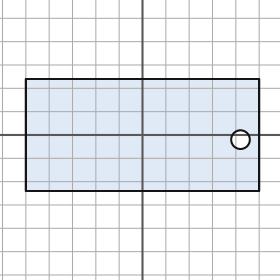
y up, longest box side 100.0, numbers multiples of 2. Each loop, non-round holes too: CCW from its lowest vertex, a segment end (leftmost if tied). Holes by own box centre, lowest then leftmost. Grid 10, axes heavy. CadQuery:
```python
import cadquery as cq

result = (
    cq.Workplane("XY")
    .moveTo(-50.0, -24.0)
    .lineTo(50.0, -24.0)
    .lineTo(50.0, 24.0)
    .lineTo(-50.0, 24.0)
    .close()
    .moveTo(42.0, -2.0)
    .circle(4.0)
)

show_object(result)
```